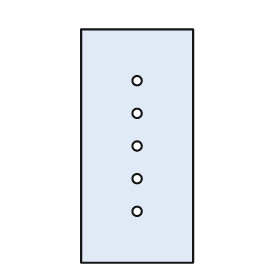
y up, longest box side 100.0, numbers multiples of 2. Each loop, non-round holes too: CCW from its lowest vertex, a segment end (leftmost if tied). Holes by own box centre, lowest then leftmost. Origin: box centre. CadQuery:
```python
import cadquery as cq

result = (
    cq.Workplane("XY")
    .moveTo(-24.0, -50.0)
    .lineTo(24.0, -50.0)
    .lineTo(24.0, 50.0)
    .lineTo(-24.0, 50.0)
    .close()
    .moveTo(0.0, -28.0)
    .circle(2.0)
    .moveTo(0.0, -14.0)
    .circle(2.0)
    .moveTo(0.0, 0.0)
    .circle(2.0)
    .moveTo(0.0, 14.0)
    .circle(2.0)
    .moveTo(0.0, 28.0)
    .circle(2.0)
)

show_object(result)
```